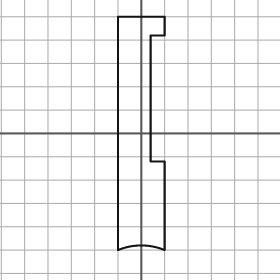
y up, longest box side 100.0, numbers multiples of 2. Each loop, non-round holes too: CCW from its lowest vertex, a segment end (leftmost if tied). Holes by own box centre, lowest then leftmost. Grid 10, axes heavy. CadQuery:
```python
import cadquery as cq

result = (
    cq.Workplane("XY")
    .moveTo(-10.0, -50.0)
    .threePointArc((0.0, -48.0), (10.0, -50.0))
    .lineTo(10.0, -12.0)
    .lineTo(4.0, -12.0)
    .lineTo(4.0, 42.0)
    .lineTo(10.0, 42.0)
    .lineTo(10.0, 50.0)
    .lineTo(-10.0, 50.0)
    .close()
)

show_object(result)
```